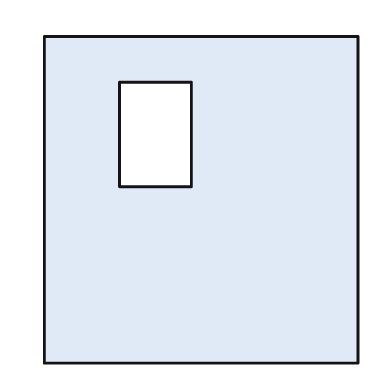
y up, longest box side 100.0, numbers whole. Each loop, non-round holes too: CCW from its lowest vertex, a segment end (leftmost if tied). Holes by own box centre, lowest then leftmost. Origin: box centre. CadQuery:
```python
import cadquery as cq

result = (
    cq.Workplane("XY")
    .moveTo(-48.0, -50.0)
    .lineTo(48.0, -50.0)
    .lineTo(48.0, 50.0)
    .lineTo(-48.0, 50.0)
    .close()
    .moveTo(-25.0, 4.0)
    .lineTo(-3.0, 4.0)
    .lineTo(-3.0, 36.0)
    .lineTo(-25.0, 36.0)
    .close()
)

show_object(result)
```